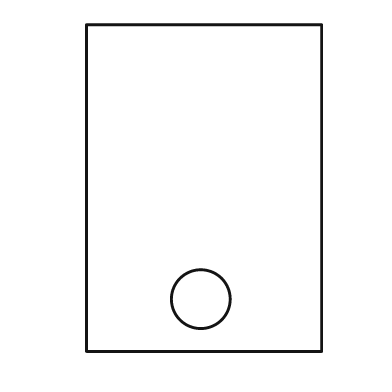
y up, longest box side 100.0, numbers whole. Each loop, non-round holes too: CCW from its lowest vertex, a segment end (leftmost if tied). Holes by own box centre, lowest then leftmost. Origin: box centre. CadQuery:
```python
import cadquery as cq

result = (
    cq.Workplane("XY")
    .moveTo(-36.0, -50.0)
    .lineTo(36.0, -50.0)
    .lineTo(36.0, 50.0)
    .lineTo(-36.0, 50.0)
    .close()
    .moveTo(-1.0, -34.0)
    .circle(9.0)
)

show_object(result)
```